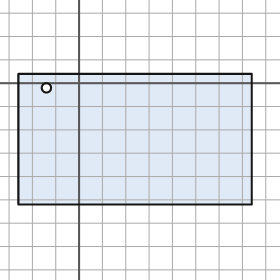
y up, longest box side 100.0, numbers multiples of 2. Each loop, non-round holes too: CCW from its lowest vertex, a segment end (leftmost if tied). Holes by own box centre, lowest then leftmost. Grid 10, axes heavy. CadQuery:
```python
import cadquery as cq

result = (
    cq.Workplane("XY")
    .moveTo(-26.0, -52.0)
    .lineTo(74.0, -52.0)
    .lineTo(74.0, 4.0)
    .lineTo(-26.0, 4.0)
    .close()
    .moveTo(-14.0, -2.0)
    .circle(2.0)
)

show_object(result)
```